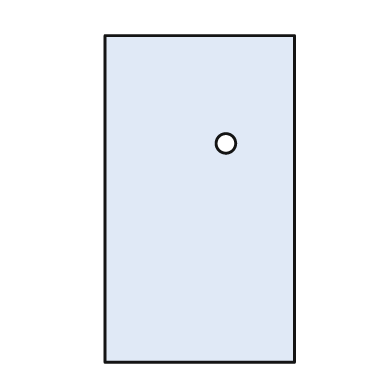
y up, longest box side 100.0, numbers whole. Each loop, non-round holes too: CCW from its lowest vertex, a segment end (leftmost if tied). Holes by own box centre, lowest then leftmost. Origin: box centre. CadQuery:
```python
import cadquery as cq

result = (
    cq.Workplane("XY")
    .moveTo(-29.0, -50.0)
    .lineTo(29.0, -50.0)
    .lineTo(29.0, 50.0)
    .lineTo(-29.0, 50.0)
    .close()
    .moveTo(8.0, 17.0)
    .circle(3.0)
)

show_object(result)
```